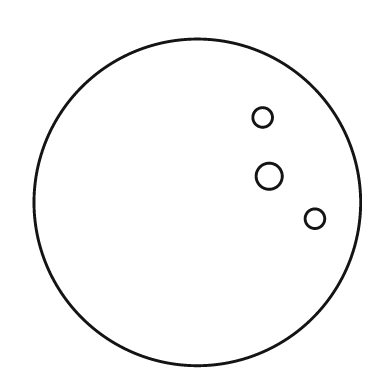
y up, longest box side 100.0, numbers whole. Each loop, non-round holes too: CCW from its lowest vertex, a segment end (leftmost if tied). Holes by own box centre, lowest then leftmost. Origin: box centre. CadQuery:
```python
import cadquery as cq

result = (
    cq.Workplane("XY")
    .moveTo(0.0, 0.0)
    .circle(50.0)
    .moveTo(36.0, -5.0)
    .circle(3.0)
    .moveTo(22.0, 8.0)
    .circle(4.0)
    .moveTo(20.0, 26.0)
    .circle(3.0)
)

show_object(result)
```